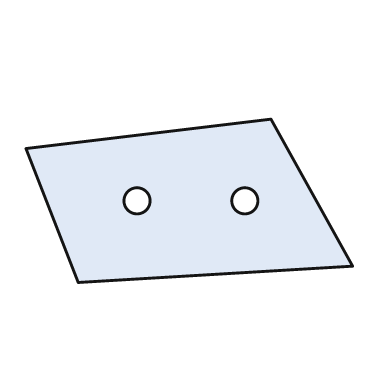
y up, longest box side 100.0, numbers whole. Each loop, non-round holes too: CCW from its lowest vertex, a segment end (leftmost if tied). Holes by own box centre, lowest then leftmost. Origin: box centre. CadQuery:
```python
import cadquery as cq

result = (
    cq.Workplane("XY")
    .moveTo(-34.0, -25.0)
    .lineTo(50.0, -20.0)
    .lineTo(25.0, 25.0)
    .lineTo(-50.0, 16.0)
    .close()
    .moveTo(-16.0, 0.0)
    .circle(4.0)
    .moveTo(17.0, 0.0)
    .circle(4.0)
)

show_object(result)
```